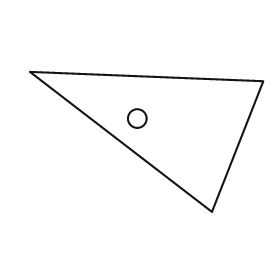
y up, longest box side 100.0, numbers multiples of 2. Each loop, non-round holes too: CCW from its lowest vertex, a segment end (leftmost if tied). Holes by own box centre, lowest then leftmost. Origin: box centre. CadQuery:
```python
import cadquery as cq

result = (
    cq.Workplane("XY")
    .moveTo(28.0, -30.0)
    .lineTo(50.0, 26.0)
    .lineTo(-50.0, 30.0)
    .close()
    .moveTo(-4.0, 10.0)
    .circle(4.0)
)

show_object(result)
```